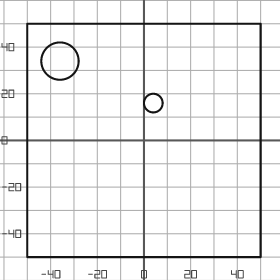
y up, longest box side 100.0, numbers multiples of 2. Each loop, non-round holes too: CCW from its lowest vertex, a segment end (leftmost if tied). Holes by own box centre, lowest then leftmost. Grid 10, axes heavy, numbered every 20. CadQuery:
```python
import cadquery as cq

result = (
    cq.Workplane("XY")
    .moveTo(-50.0, -50.0)
    .lineTo(50.0, -50.0)
    .lineTo(50.0, 50.0)
    .lineTo(-50.0, 50.0)
    .close()
    .moveTo(4.0, 16.0)
    .circle(4.0)
    .moveTo(-36.0, 34.0)
    .circle(8.0)
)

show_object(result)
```